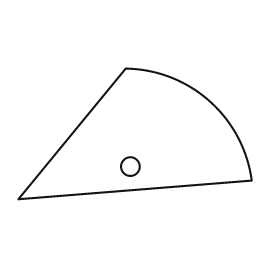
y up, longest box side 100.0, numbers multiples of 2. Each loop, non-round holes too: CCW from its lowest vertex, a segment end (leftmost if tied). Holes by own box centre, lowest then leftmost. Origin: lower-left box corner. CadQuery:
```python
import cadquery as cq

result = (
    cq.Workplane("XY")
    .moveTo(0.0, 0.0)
    .lineTo(100.0, 8.0)
    .threePointArc((82.0, 42.0), (46.0, 56.0))
    .close()
    .moveTo(48.0, 14.0)
    .circle(4.0)
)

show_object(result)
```